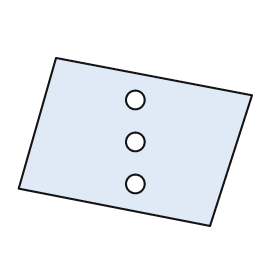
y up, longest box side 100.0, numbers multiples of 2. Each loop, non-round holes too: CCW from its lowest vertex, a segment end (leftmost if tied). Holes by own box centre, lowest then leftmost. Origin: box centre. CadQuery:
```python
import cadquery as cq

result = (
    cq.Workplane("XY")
    .moveTo(32.0, -36.0)
    .lineTo(50.0, 20.0)
    .lineTo(-34.0, 36.0)
    .lineTo(-50.0, -20.0)
    .close()
    .moveTo(0.0, -18.0)
    .circle(4.0)
    .moveTo(0.0, 0.0)
    .circle(4.0)
    .moveTo(0.0, 18.0)
    .circle(4.0)
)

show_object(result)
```